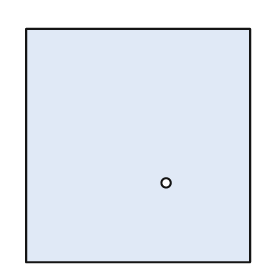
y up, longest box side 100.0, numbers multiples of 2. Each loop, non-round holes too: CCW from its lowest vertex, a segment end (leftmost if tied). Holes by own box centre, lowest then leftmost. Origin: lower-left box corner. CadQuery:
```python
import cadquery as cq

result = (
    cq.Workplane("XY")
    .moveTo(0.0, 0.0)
    .lineTo(96.0, 0.0)
    .lineTo(96.0, 100.0)
    .lineTo(0.0, 100.0)
    .close()
    .moveTo(60.0, 34.0)
    .circle(2.0)
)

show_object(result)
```